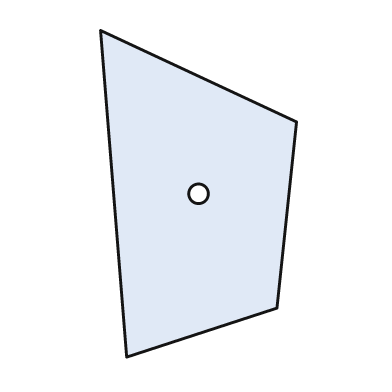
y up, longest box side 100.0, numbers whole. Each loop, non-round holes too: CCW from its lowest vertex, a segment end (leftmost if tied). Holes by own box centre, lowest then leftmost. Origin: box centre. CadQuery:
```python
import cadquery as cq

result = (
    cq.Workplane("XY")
    .moveTo(-22.0, -50.0)
    .lineTo(24.0, -35.0)
    .lineTo(30.0, 22.0)
    .lineTo(-30.0, 50.0)
    .close()
    .moveTo(0.0, 0.0)
    .circle(3.0)
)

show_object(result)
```